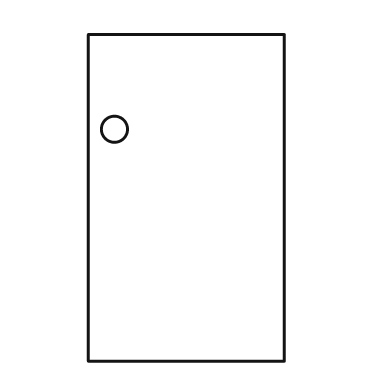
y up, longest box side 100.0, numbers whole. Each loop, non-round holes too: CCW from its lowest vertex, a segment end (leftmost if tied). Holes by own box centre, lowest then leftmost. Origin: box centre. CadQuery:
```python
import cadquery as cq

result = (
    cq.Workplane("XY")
    .moveTo(-30.0, -50.0)
    .lineTo(30.0, -50.0)
    .lineTo(30.0, 50.0)
    .lineTo(-30.0, 50.0)
    .close()
    .moveTo(-22.0, 21.0)
    .circle(4.0)
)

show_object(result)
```